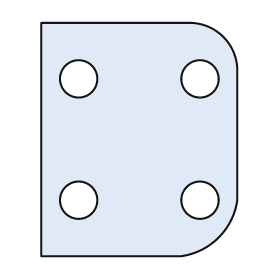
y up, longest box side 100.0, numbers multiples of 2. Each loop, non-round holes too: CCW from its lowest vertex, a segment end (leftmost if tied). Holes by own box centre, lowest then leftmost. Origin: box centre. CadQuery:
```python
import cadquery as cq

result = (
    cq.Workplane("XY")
    .moveTo(-42.0, -50.0)
    .lineTo(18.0, -50.0)
    .threePointArc((34.0, -42.0), (42.0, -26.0))
    .lineTo(42.0, 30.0)
    .threePointArc((36.0, 44.0), (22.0, 50.0))
    .lineTo(-42.0, 50.0)
    .close()
    .moveTo(-26.0, -26.0)
    .circle(8.0)
    .moveTo(26.0, -26.0)
    .circle(8.0)
    .moveTo(-26.0, 26.0)
    .circle(8.0)
    .moveTo(26.0, 26.0)
    .circle(8.0)
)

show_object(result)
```